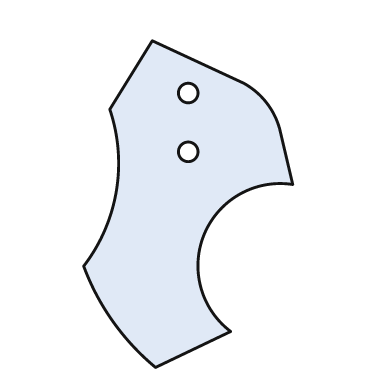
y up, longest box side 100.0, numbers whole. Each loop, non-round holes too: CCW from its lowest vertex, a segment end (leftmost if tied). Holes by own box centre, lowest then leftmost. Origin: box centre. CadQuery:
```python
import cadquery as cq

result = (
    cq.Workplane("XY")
    .moveTo(-10.0, -50.0)
    .lineTo(13.0, -39.0)
    .threePointArc((5.0, -9.0), (32.0, 6.0))
    .lineTo(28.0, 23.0)
    .threePointArc((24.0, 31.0), (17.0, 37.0))
    .lineTo(-11.0, 50.0)
    .lineTo(-24.0, 29.0)
    .threePointArc((-22.0, 4.0), (-32.0, -19.0))
    .threePointArc((-23.0, -36.0), (-10.0, -50.0))
    .close()
    .moveTo(0.0, 16.0)
    .circle(3.0)
    .moveTo(0.0, 34.0)
    .circle(3.0)
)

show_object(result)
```